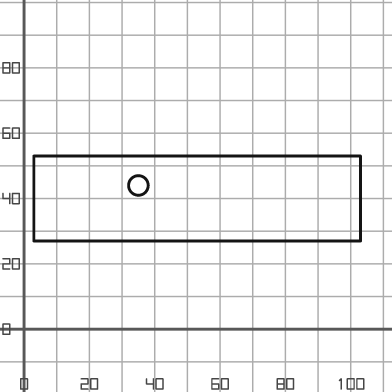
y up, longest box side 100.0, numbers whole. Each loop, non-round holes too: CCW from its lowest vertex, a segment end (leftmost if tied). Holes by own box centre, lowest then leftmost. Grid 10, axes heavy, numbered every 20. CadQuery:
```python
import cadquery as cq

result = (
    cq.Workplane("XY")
    .moveTo(3.0, 27.0)
    .lineTo(103.0, 27.0)
    .lineTo(103.0, 53.0)
    .lineTo(3.0, 53.0)
    .close()
    .moveTo(35.0, 44.0)
    .circle(3.0)
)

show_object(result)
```